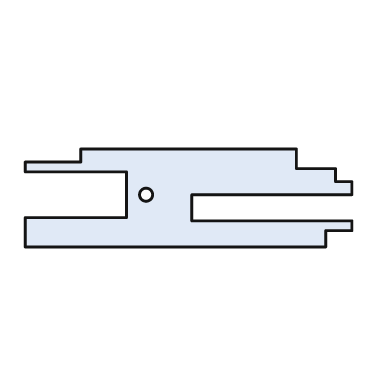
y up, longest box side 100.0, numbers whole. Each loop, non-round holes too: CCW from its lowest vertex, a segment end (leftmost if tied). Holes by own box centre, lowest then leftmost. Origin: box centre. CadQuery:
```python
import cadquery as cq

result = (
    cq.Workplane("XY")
    .moveTo(-50.0, -15.0)
    .lineTo(42.0, -15.0)
    .lineTo(42.0, -10.0)
    .lineTo(50.0, -10.0)
    .lineTo(50.0, -7.0)
    .lineTo(1.0, -7.0)
    .lineTo(1.0, 1.0)
    .lineTo(50.0, 1.0)
    .lineTo(50.0, 5.0)
    .lineTo(45.0, 5.0)
    .lineTo(45.0, 9.0)
    .lineTo(33.0, 9.0)
    .lineTo(33.0, 15.0)
    .lineTo(-33.0, 15.0)
    .lineTo(-33.0, 11.0)
    .lineTo(-50.0, 11.0)
    .lineTo(-50.0, 8.0)
    .lineTo(-19.0, 8.0)
    .lineTo(-19.0, -6.0)
    .lineTo(-50.0, -6.0)
    .close()
    .moveTo(-13.0, 1.0)
    .circle(2.0)
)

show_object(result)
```